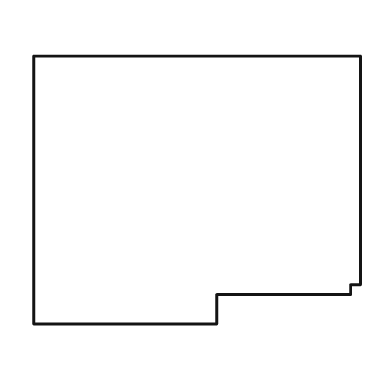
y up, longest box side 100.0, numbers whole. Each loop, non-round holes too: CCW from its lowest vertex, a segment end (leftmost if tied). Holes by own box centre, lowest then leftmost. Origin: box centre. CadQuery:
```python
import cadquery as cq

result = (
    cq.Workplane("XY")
    .moveTo(-50.0, -41.0)
    .lineTo(6.0, -41.0)
    .lineTo(6.0, -32.0)
    .lineTo(47.0, -32.0)
    .lineTo(47.0, -29.0)
    .lineTo(50.0, -29.0)
    .lineTo(50.0, 41.0)
    .lineTo(-50.0, 41.0)
    .close()
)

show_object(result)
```